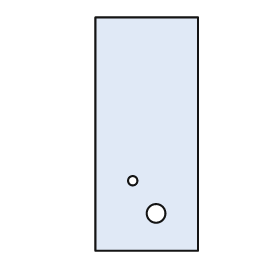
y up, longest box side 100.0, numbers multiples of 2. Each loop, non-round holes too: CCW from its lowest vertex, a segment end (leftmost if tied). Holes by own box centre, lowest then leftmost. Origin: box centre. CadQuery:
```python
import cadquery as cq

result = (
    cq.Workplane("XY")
    .moveTo(-22.0, -50.0)
    .lineTo(22.0, -50.0)
    .lineTo(22.0, 50.0)
    .lineTo(-22.0, 50.0)
    .close()
    .moveTo(4.0, -34.0)
    .circle(4.0)
    .moveTo(-6.0, -20.0)
    .circle(2.0)
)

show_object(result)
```